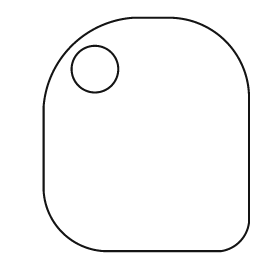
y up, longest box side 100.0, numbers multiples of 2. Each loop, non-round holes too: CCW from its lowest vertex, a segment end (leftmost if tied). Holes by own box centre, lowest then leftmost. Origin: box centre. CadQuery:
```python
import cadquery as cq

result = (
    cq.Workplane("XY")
    .moveTo(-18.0, -50.0)
    .lineTo(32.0, -50.0)
    .threePointArc((40.0, -46.0), (44.0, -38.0))
    .lineTo(44.0, 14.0)
    .threePointArc((34.0, 40.0), (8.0, 50.0))
    .lineTo(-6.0, 50.0)
    .threePointArc((-32.0, 38.0), (-44.0, 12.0))
    .lineTo(-44.0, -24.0)
    .threePointArc((-36.0, -42.0), (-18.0, -50.0))
    .close()
    .moveTo(-22.0, 28.0)
    .circle(10.0)
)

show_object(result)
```